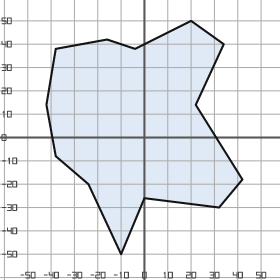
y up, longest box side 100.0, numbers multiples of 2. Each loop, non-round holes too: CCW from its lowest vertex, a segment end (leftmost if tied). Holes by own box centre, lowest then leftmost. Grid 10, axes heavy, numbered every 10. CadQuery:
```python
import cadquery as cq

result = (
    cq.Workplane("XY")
    .moveTo(-10.0, -50.0)
    .lineTo(0.0, -26.0)
    .lineTo(32.0, -30.0)
    .lineTo(42.0, -18.0)
    .lineTo(22.0, 14.0)
    .lineTo(34.0, 40.0)
    .lineTo(20.0, 50.0)
    .lineTo(-4.0, 38.0)
    .lineTo(-16.0, 42.0)
    .lineTo(-38.0, 38.0)
    .lineTo(-42.0, 14.0)
    .lineTo(-38.0, -8.0)
    .lineTo(-24.0, -20.0)
    .close()
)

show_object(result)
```